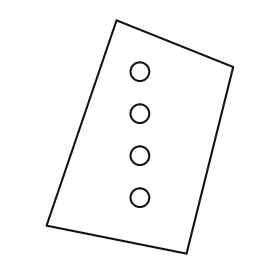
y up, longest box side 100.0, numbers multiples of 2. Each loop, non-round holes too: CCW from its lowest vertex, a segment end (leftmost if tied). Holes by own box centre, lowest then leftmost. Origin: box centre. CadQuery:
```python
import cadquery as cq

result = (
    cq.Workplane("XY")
    .moveTo(20.0, -50.0)
    .lineTo(40.0, 30.0)
    .lineTo(-10.0, 50.0)
    .lineTo(-40.0, -38.0)
    .close()
    .moveTo(0.0, -26.0)
    .circle(4.0)
    .moveTo(0.0, -8.0)
    .circle(4.0)
    .moveTo(0.0, 10.0)
    .circle(4.0)
    .moveTo(0.0, 28.0)
    .circle(4.0)
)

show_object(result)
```